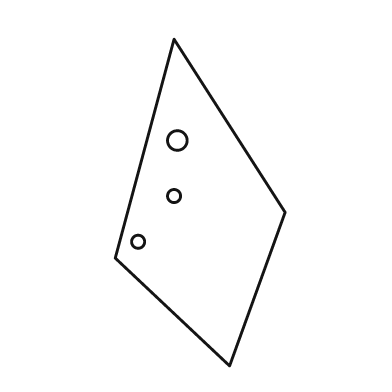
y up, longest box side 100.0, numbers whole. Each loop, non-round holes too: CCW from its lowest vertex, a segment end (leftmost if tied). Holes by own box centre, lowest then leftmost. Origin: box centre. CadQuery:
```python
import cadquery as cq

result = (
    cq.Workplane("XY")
    .moveTo(9.0, -50.0)
    .lineTo(26.0, -3.0)
    .lineTo(-8.0, 50.0)
    .lineTo(-26.0, -17.0)
    .close()
    .moveTo(-19.0, -12.0)
    .circle(2.0)
    .moveTo(-8.0, 2.0)
    .circle(2.0)
    .moveTo(-7.0, 19.0)
    .circle(3.0)
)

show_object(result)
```